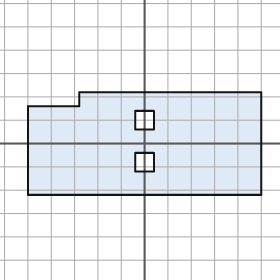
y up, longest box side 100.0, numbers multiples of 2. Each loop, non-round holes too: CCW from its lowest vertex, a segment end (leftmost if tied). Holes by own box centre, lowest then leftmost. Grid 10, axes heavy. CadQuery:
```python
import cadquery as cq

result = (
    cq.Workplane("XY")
    .moveTo(-50.0, -22.0)
    .lineTo(50.0, -22.0)
    .lineTo(50.0, 22.0)
    .lineTo(-28.0, 22.0)
    .lineTo(-28.0, 16.0)
    .lineTo(-50.0, 16.0)
    .close()
    .moveTo(-4.0, -12.0)
    .lineTo(4.0, -12.0)
    .lineTo(4.0, -4.0)
    .lineTo(-4.0, -4.0)
    .close()
    .moveTo(-4.0, 6.0)
    .lineTo(4.0, 6.0)
    .lineTo(4.0, 14.0)
    .lineTo(-4.0, 14.0)
    .close()
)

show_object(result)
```